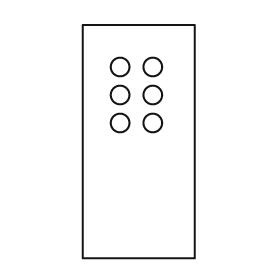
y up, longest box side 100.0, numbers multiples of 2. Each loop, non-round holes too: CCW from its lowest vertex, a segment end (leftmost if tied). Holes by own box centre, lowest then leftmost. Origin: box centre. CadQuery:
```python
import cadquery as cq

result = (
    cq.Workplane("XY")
    .moveTo(-24.0, -50.0)
    .lineTo(24.0, -50.0)
    .lineTo(24.0, 50.0)
    .lineTo(-24.0, 50.0)
    .close()
    .moveTo(-8.0, 8.0)
    .circle(4.0)
    .moveTo(6.0, 8.0)
    .circle(4.0)
    .moveTo(-8.0, 20.0)
    .circle(4.0)
    .moveTo(6.0, 20.0)
    .circle(4.0)
    .moveTo(-8.0, 32.0)
    .circle(4.0)
    .moveTo(6.0, 32.0)
    .circle(4.0)
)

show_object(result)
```